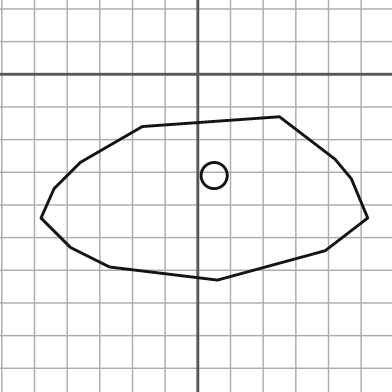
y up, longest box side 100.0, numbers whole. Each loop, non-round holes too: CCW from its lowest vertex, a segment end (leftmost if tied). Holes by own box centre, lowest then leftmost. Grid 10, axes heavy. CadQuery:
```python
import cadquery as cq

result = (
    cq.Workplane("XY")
    .moveTo(6.0, -63.0)
    .lineTo(39.0, -54.0)
    .lineTo(52.0, -44.0)
    .lineTo(47.0, -32.0)
    .lineTo(42.0, -26.0)
    .lineTo(25.0, -13.0)
    .lineTo(-17.0, -16.0)
    .lineTo(-36.0, -27.0)
    .lineTo(-44.0, -35.0)
    .lineTo(-48.0, -44.0)
    .lineTo(-39.0, -53.0)
    .lineTo(-27.0, -59.0)
    .close()
    .moveTo(5.0, -31.0)
    .circle(4.0)
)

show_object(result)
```